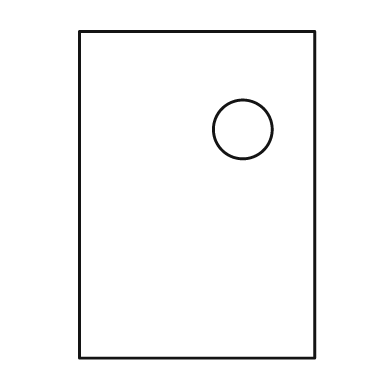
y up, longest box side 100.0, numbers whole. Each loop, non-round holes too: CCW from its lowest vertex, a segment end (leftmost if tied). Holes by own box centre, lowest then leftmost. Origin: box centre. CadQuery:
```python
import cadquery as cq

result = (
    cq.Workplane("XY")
    .moveTo(-36.0, -50.0)
    .lineTo(36.0, -50.0)
    .lineTo(36.0, 50.0)
    .lineTo(-36.0, 50.0)
    .close()
    .moveTo(14.0, 20.0)
    .circle(9.0)
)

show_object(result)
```